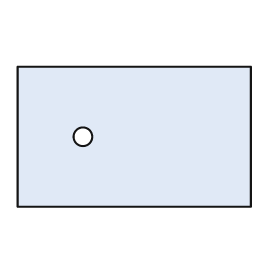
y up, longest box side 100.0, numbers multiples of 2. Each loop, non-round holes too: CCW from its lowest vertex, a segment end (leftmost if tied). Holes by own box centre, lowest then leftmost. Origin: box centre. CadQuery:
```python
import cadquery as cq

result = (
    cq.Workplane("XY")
    .moveTo(-50.0, -30.0)
    .lineTo(50.0, -30.0)
    .lineTo(50.0, 30.0)
    .lineTo(-50.0, 30.0)
    .close()
    .moveTo(-22.0, 0.0)
    .circle(4.0)
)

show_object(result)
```